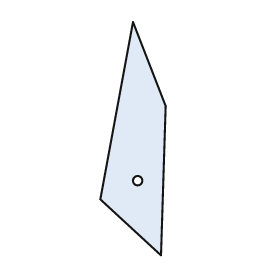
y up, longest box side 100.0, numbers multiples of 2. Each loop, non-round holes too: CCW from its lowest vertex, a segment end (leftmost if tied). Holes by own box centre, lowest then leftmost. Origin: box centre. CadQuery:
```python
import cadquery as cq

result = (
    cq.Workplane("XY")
    .moveTo(12.0, -50.0)
    .lineTo(14.0, 14.0)
    .lineTo(0.0, 50.0)
    .lineTo(-14.0, -26.0)
    .close()
    .moveTo(2.0, -18.0)
    .circle(2.0)
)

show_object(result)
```